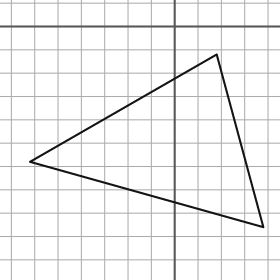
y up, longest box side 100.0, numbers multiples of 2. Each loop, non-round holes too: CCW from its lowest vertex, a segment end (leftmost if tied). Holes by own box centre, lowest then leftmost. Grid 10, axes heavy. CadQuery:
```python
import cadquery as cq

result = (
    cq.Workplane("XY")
    .moveTo(38.0, -86.0)
    .lineTo(18.0, -12.0)
    .lineTo(-62.0, -58.0)
    .close()
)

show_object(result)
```